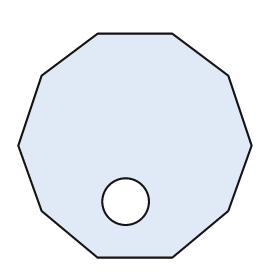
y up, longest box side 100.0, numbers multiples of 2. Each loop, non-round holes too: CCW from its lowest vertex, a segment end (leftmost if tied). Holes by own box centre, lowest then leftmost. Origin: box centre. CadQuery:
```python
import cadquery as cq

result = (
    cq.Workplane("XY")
    .moveTo(-16.0, -48.0)
    .lineTo(16.0, -48.0)
    .lineTo(40.0, -28.0)
    .lineTo(50.0, 0.0)
    .lineTo(40.0, 30.0)
    .lineTo(16.0, 48.0)
    .lineTo(-16.0, 48.0)
    .lineTo(-40.0, 30.0)
    .lineTo(-50.0, 0.0)
    .lineTo(-40.0, -28.0)
    .close()
    .moveTo(-4.0, -24.0)
    .circle(10.0)
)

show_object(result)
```